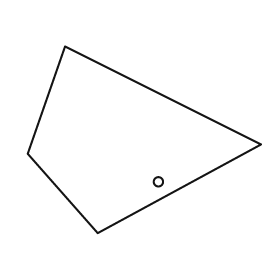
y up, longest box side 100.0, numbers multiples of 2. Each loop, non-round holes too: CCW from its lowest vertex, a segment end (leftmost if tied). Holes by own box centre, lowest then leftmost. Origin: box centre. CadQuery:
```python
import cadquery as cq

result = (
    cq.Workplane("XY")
    .moveTo(-20.0, -40.0)
    .lineTo(50.0, -2.0)
    .lineTo(-34.0, 40.0)
    .lineTo(-50.0, -6.0)
    .close()
    .moveTo(6.0, -18.0)
    .circle(2.0)
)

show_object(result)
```